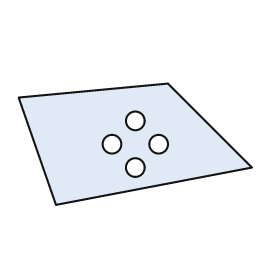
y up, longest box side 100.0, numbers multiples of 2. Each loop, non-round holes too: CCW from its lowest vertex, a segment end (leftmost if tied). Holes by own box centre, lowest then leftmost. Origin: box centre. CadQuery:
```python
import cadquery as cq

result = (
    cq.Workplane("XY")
    .moveTo(-34.0, -26.0)
    .lineTo(50.0, -10.0)
    .lineTo(14.0, 26.0)
    .lineTo(-50.0, 20.0)
    .close()
    .moveTo(0.0, -10.0)
    .circle(4.0)
    .moveTo(-10.0, 0.0)
    .circle(4.0)
    .moveTo(10.0, 0.0)
    .circle(4.0)
    .moveTo(0.0, 10.0)
    .circle(4.0)
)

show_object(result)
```